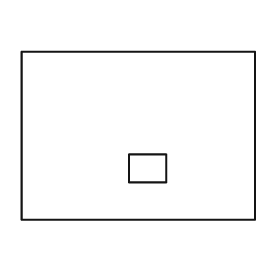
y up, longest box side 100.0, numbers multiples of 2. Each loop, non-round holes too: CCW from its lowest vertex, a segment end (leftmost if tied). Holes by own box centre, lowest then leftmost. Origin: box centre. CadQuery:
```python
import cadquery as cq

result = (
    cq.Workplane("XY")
    .moveTo(-50.0, -36.0)
    .lineTo(50.0, -36.0)
    .lineTo(50.0, 36.0)
    .lineTo(-50.0, 36.0)
    .close()
    .moveTo(-4.0, -20.0)
    .lineTo(12.0, -20.0)
    .lineTo(12.0, -8.0)
    .lineTo(-4.0, -8.0)
    .close()
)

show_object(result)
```